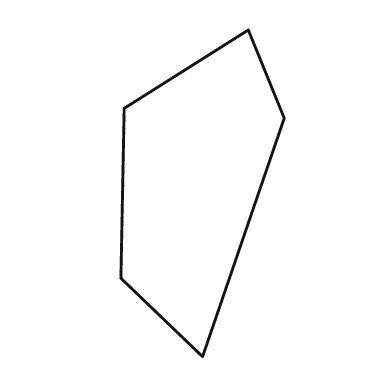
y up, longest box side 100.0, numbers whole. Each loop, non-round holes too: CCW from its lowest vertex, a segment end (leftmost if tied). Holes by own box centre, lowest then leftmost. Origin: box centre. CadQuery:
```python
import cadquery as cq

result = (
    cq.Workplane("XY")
    .moveTo(0.0, -50.0)
    .lineTo(25.0, 23.0)
    .lineTo(14.0, 50.0)
    .lineTo(-24.0, 26.0)
    .lineTo(-25.0, -26.0)
    .close()
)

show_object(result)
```